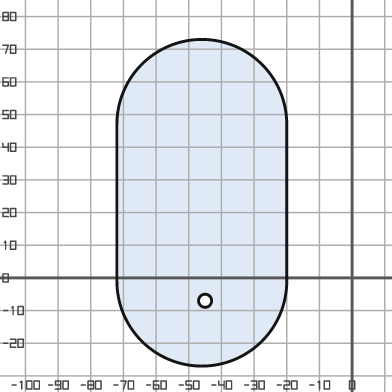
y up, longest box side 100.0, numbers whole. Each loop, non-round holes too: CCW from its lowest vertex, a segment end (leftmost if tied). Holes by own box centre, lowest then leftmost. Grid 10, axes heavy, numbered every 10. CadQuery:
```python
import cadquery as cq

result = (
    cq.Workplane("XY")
    .moveTo(-72.0, -1.0)
    .threePointArc((-46.0, -27.0), (-20.0, -1.0))
    .lineTo(-20.0, 47.0)
    .threePointArc((-46.0, 73.0), (-72.0, 47.0))
    .close()
    .moveTo(-45.0, -7.0)
    .circle(2.0)
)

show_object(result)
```